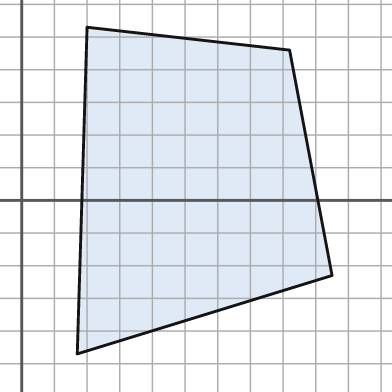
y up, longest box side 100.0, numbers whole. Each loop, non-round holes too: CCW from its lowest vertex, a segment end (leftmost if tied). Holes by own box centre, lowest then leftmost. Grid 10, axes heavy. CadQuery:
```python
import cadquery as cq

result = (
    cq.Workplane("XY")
    .moveTo(17.0, -47.0)
    .lineTo(95.0, -23.0)
    .lineTo(82.0, 46.0)
    .lineTo(20.0, 53.0)
    .close()
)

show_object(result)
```